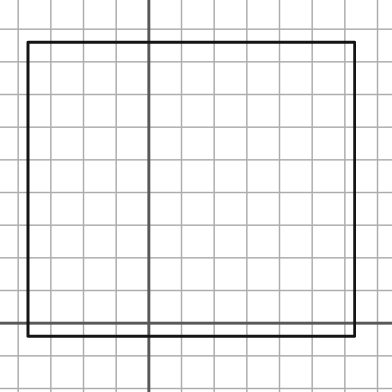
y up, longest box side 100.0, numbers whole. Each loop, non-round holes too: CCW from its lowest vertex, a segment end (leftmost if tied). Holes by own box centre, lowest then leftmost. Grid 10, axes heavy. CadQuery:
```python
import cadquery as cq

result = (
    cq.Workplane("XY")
    .moveTo(-37.0, -4.0)
    .lineTo(63.0, -4.0)
    .lineTo(63.0, 86.0)
    .lineTo(-37.0, 86.0)
    .close()
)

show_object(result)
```